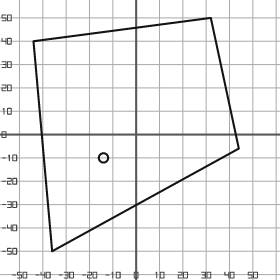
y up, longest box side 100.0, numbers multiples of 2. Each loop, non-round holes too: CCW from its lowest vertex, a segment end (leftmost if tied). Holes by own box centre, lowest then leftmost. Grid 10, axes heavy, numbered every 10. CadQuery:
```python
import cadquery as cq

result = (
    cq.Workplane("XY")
    .moveTo(-36.0, -50.0)
    .lineTo(44.0, -6.0)
    .lineTo(32.0, 50.0)
    .lineTo(-44.0, 40.0)
    .close()
    .moveTo(-14.0, -10.0)
    .circle(2.0)
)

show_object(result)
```